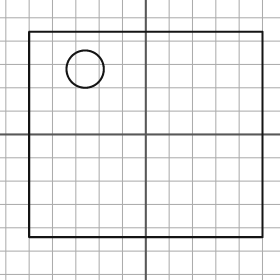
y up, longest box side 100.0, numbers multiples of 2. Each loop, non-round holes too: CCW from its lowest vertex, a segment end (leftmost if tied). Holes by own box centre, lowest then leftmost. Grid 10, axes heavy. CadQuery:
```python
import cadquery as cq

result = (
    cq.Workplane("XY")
    .moveTo(-50.0, -44.0)
    .lineTo(50.0, -44.0)
    .lineTo(50.0, 44.0)
    .lineTo(-50.0, 44.0)
    .close()
    .moveTo(-26.0, 28.0)
    .circle(8.0)
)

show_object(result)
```